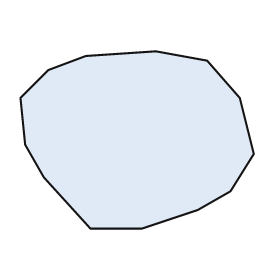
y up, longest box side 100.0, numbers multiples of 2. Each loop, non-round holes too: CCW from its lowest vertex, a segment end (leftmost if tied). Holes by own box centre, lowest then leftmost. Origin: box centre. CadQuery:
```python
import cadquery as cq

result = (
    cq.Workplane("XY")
    .moveTo(-20.0, -38.0)
    .lineTo(2.0, -38.0)
    .lineTo(26.0, -30.0)
    .lineTo(40.0, -22.0)
    .lineTo(50.0, -6.0)
    .lineTo(44.0, 18.0)
    .lineTo(30.0, 34.0)
    .lineTo(8.0, 38.0)
    .lineTo(-22.0, 36.0)
    .lineTo(-38.0, 30.0)
    .lineTo(-50.0, 18.0)
    .lineTo(-48.0, -2.0)
    .lineTo(-40.0, -16.0)
    .close()
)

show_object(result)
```